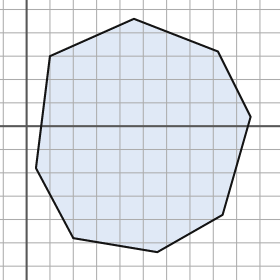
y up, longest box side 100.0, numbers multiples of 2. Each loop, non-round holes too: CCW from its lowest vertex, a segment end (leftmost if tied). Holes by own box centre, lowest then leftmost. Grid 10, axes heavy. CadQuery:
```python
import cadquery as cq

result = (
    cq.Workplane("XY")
    .moveTo(56.0, -54.0)
    .lineTo(84.0, -38.0)
    .lineTo(96.0, 4.0)
    .lineTo(82.0, 32.0)
    .lineTo(46.0, 46.0)
    .lineTo(10.0, 30.0)
    .lineTo(4.0, -18.0)
    .lineTo(20.0, -48.0)
    .close()
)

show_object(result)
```